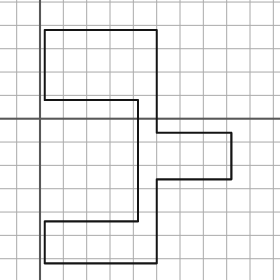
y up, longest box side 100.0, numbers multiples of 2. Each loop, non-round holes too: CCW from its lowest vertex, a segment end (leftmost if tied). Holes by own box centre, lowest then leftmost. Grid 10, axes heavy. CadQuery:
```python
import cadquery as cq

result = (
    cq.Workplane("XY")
    .moveTo(2.0, -62.0)
    .lineTo(50.0, -62.0)
    .lineTo(50.0, -26.0)
    .lineTo(82.0, -26.0)
    .lineTo(82.0, -6.0)
    .lineTo(50.0, -6.0)
    .lineTo(50.0, 38.0)
    .lineTo(2.0, 38.0)
    .lineTo(2.0, 8.0)
    .lineTo(42.0, 8.0)
    .lineTo(42.0, -44.0)
    .lineTo(2.0, -44.0)
    .close()
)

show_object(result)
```